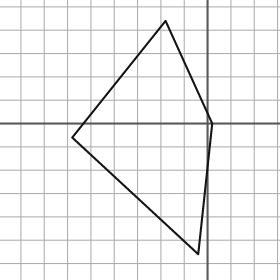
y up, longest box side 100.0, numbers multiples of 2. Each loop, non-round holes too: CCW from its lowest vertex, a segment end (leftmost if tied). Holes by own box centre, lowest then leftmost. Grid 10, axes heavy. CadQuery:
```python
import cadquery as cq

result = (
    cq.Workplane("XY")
    .moveTo(-4.0, -56.0)
    .lineTo(2.0, 0.0)
    .lineTo(-18.0, 44.0)
    .lineTo(-58.0, -6.0)
    .close()
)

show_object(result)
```